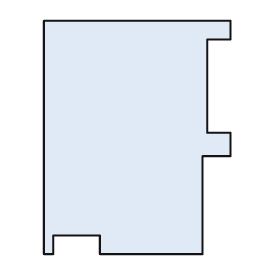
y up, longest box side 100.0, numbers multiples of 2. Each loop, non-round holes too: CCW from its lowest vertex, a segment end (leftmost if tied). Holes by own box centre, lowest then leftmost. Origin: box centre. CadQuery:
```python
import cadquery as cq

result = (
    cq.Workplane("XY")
    .moveTo(-40.0, -50.0)
    .lineTo(-36.0, -50.0)
    .lineTo(-36.0, -42.0)
    .lineTo(-16.0, -42.0)
    .lineTo(-16.0, -50.0)
    .lineTo(28.0, -50.0)
    .lineTo(28.0, -8.0)
    .lineTo(40.0, -8.0)
    .lineTo(40.0, 2.0)
    .lineTo(30.0, 2.0)
    .lineTo(30.0, 42.0)
    .lineTo(40.0, 42.0)
    .lineTo(40.0, 50.0)
    .lineTo(-40.0, 50.0)
    .close()
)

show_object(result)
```